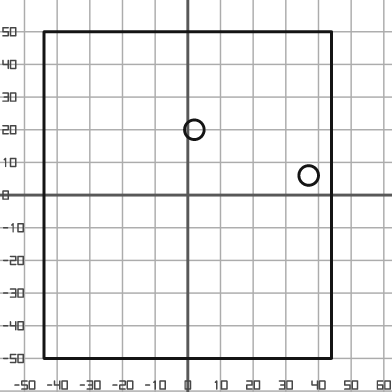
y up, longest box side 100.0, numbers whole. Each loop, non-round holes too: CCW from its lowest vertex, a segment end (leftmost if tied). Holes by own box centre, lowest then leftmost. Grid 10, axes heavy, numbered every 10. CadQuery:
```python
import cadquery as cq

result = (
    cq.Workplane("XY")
    .moveTo(-44.0, -50.0)
    .lineTo(44.0, -50.0)
    .lineTo(44.0, 50.0)
    .lineTo(-44.0, 50.0)
    .close()
    .moveTo(37.0, 6.0)
    .circle(3.0)
    .moveTo(2.0, 20.0)
    .circle(3.0)
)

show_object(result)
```